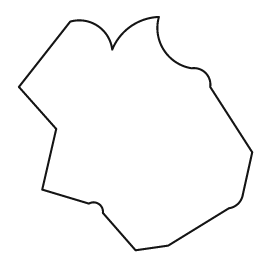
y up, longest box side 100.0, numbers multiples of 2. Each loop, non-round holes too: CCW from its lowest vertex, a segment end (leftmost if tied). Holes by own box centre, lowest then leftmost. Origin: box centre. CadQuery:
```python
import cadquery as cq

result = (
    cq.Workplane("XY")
    .moveTo(0.0, -50.0)
    .lineTo(14.0, -48.0)
    .lineTo(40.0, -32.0)
    .threePointArc((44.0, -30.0), (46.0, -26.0))
    .lineTo(50.0, -8.0)
    .lineTo(32.0, 20.0)
    .threePointArc((30.0, 26.0), (24.0, 28.0))
    .threePointArc((12.0, 36.0), (10.0, 50.0))
    .threePointArc((-2.0, 46.0), (-10.0, 36.0))
    .threePointArc((-16.0, 46.0), (-28.0, 48.0))
    .lineTo(-50.0, 20.0)
    .lineTo(-34.0, 2.0)
    .lineTo(-40.0, -24.0)
    .lineTo(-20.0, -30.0)
    .threePointArc((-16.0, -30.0), (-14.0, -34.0))
    .close()
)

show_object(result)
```